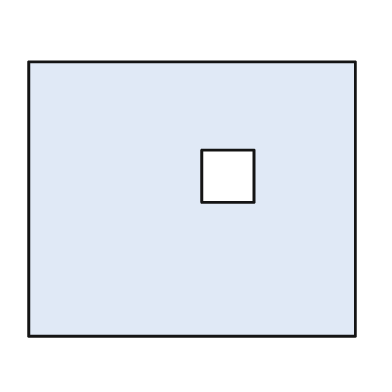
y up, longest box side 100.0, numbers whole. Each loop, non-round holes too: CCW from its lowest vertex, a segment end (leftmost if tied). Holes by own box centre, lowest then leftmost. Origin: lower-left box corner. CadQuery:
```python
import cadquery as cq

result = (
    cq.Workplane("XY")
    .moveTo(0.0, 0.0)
    .lineTo(100.0, 0.0)
    .lineTo(100.0, 84.0)
    .lineTo(0.0, 84.0)
    .close()
    .moveTo(53.0, 41.0)
    .lineTo(69.0, 41.0)
    .lineTo(69.0, 57.0)
    .lineTo(53.0, 57.0)
    .close()
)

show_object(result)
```